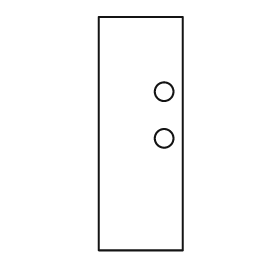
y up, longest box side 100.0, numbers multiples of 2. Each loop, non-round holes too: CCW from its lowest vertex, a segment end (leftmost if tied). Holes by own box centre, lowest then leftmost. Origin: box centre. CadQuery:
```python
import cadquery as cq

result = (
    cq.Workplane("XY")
    .moveTo(-18.0, -50.0)
    .lineTo(18.0, -50.0)
    .lineTo(18.0, 50.0)
    .lineTo(-18.0, 50.0)
    .close()
    .moveTo(10.0, -2.0)
    .circle(4.0)
    .moveTo(10.0, 18.0)
    .circle(4.0)
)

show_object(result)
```